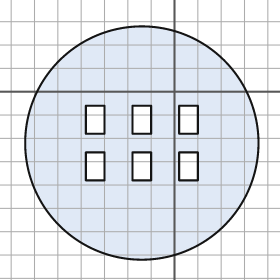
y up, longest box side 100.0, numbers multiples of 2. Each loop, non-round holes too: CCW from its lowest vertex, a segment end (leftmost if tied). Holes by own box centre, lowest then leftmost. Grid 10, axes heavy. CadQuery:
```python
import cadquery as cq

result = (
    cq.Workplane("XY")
    .moveTo(-14.0, -22.0)
    .circle(50.0)
    .moveTo(-38.0, -38.0)
    .lineTo(-30.0, -38.0)
    .lineTo(-30.0, -26.0)
    .lineTo(-38.0, -26.0)
    .close()
    .moveTo(-18.0, -38.0)
    .lineTo(-10.0, -38.0)
    .lineTo(-10.0, -26.0)
    .lineTo(-18.0, -26.0)
    .close()
    .moveTo(2.0, -38.0)
    .lineTo(10.0, -38.0)
    .lineTo(10.0, -26.0)
    .lineTo(2.0, -26.0)
    .close()
    .moveTo(-38.0, -18.0)
    .lineTo(-30.0, -18.0)
    .lineTo(-30.0, -6.0)
    .lineTo(-38.0, -6.0)
    .close()
    .moveTo(-18.0, -18.0)
    .lineTo(-10.0, -18.0)
    .lineTo(-10.0, -6.0)
    .lineTo(-18.0, -6.0)
    .close()
    .moveTo(2.0, -18.0)
    .lineTo(10.0, -18.0)
    .lineTo(10.0, -6.0)
    .lineTo(2.0, -6.0)
    .close()
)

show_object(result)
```